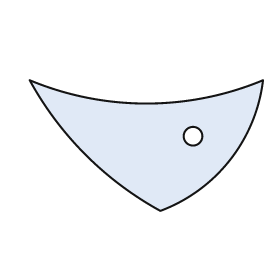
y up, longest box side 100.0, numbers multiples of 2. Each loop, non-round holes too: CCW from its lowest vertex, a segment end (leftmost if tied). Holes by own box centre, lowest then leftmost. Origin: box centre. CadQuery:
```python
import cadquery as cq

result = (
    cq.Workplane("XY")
    .moveTo(6.0, -28.0)
    .threePointArc((36.0, -6.0), (50.0, 28.0))
    .threePointArc((0.0, 18.0), (-50.0, 28.0))
    .threePointArc((-26.0, -4.0), (6.0, -28.0))
    .close()
    .moveTo(20.0, 4.0)
    .circle(4.0)
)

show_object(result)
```